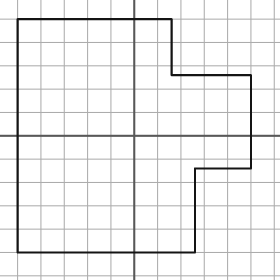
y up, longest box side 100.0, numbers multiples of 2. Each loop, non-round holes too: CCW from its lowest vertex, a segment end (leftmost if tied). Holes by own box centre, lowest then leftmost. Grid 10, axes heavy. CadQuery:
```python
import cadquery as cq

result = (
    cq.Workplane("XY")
    .moveTo(-50.0, -50.0)
    .lineTo(26.0, -50.0)
    .lineTo(26.0, -14.0)
    .lineTo(50.0, -14.0)
    .lineTo(50.0, 26.0)
    .lineTo(16.0, 26.0)
    .lineTo(16.0, 50.0)
    .lineTo(-50.0, 50.0)
    .close()
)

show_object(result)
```